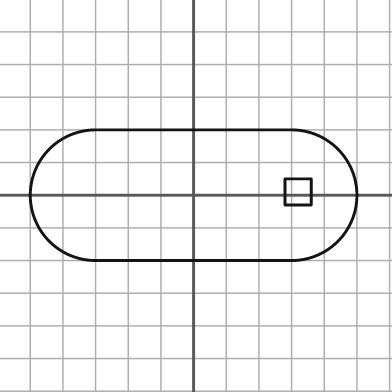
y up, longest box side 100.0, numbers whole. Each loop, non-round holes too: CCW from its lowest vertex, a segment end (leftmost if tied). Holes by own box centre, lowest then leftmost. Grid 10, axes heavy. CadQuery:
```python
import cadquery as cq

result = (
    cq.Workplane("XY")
    .moveTo(-30.0, -20.0)
    .lineTo(30.0, -20.0)
    .threePointArc((50.0, 0.0), (30.0, 20.0))
    .lineTo(-30.0, 20.0)
    .threePointArc((-50.0, 0.0), (-30.0, -20.0))
    .close()
    .moveTo(28.0, -3.0)
    .lineTo(36.0, -3.0)
    .lineTo(36.0, 5.0)
    .lineTo(28.0, 5.0)
    .close()
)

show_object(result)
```